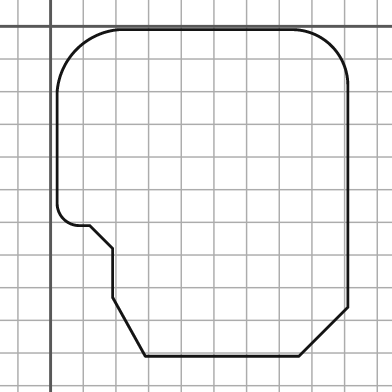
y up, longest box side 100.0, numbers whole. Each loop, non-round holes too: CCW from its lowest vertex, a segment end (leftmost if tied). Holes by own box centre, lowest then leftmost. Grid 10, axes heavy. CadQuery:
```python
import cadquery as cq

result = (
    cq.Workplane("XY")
    .moveTo(29.0, -101.0)
    .lineTo(76.0, -101.0)
    .lineTo(91.0, -86.0)
    .lineTo(91.0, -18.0)
    .threePointArc((86.0, -6.0), (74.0, -1.0))
    .lineTo(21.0, -1.0)
    .threePointArc((8.0, -7.0), (2.0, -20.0))
    .lineTo(2.0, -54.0)
    .threePointArc((4.0, -59.0), (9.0, -61.0))
    .lineTo(12.0, -61.0)
    .lineTo(19.0, -68.0)
    .lineTo(19.0, -83.0)
    .close()
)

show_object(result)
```